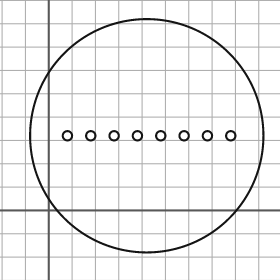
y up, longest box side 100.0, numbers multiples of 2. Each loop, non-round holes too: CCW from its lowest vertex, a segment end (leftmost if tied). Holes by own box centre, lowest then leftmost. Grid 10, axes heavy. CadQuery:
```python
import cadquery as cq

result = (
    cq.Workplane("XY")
    .moveTo(42.0, 32.0)
    .circle(50.0)
    .moveTo(8.0, 32.0)
    .circle(2.0)
    .moveTo(18.0, 32.0)
    .circle(2.0)
    .moveTo(28.0, 32.0)
    .circle(2.0)
    .moveTo(38.0, 32.0)
    .circle(2.0)
    .moveTo(48.0, 32.0)
    .circle(2.0)
    .moveTo(58.0, 32.0)
    .circle(2.0)
    .moveTo(68.0, 32.0)
    .circle(2.0)
    .moveTo(78.0, 32.0)
    .circle(2.0)
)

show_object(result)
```